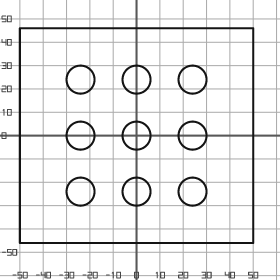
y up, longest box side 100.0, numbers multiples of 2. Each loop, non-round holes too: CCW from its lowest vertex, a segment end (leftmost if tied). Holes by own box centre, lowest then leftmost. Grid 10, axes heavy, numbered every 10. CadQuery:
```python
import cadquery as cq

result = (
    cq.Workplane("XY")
    .moveTo(-50.0, -46.0)
    .lineTo(50.0, -46.0)
    .lineTo(50.0, 46.0)
    .lineTo(-50.0, 46.0)
    .close()
    .moveTo(-24.0, -24.0)
    .circle(6.0)
    .moveTo(0.0, -24.0)
    .circle(6.0)
    .moveTo(24.0, -24.0)
    .circle(6.0)
    .moveTo(-24.0, 0.0)
    .circle(6.0)
    .moveTo(0.0, 0.0)
    .circle(6.0)
    .moveTo(24.0, 0.0)
    .circle(6.0)
    .moveTo(-24.0, 24.0)
    .circle(6.0)
    .moveTo(0.0, 24.0)
    .circle(6.0)
    .moveTo(24.0, 24.0)
    .circle(6.0)
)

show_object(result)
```